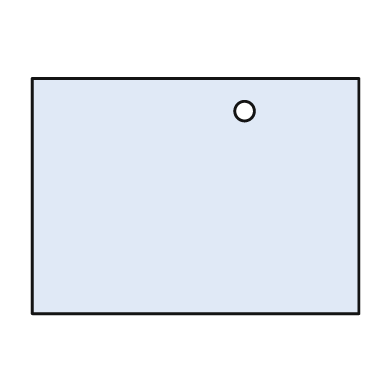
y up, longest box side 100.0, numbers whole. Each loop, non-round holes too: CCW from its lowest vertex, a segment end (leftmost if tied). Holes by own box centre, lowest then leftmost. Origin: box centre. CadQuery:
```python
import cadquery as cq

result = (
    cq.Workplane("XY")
    .moveTo(-50.0, -36.0)
    .lineTo(50.0, -36.0)
    .lineTo(50.0, 36.0)
    .lineTo(-50.0, 36.0)
    .close()
    .moveTo(15.0, 26.0)
    .circle(3.0)
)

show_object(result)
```